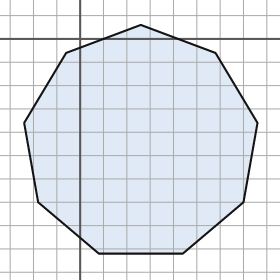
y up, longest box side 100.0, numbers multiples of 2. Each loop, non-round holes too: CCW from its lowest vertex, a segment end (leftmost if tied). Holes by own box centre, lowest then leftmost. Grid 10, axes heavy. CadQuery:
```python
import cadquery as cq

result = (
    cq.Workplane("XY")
    .moveTo(8.0, -92.0)
    .lineTo(44.0, -92.0)
    .lineTo(70.0, -70.0)
    .lineTo(76.0, -36.0)
    .lineTo(58.0, -6.0)
    .lineTo(26.0, 6.0)
    .lineTo(-6.0, -6.0)
    .lineTo(-24.0, -36.0)
    .lineTo(-18.0, -70.0)
    .close()
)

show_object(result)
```